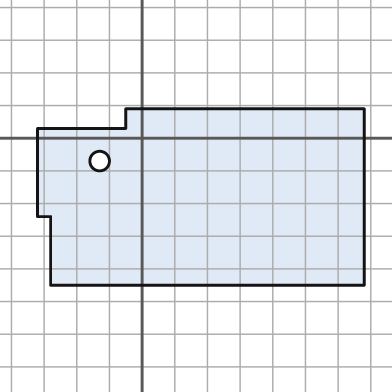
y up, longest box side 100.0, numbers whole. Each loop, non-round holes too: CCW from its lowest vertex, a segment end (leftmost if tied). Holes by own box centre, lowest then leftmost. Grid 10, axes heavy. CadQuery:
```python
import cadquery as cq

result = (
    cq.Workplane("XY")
    .moveTo(-28.0, -45.0)
    .lineTo(68.0, -45.0)
    .lineTo(68.0, 9.0)
    .lineTo(-5.0, 9.0)
    .lineTo(-5.0, 3.0)
    .lineTo(-32.0, 3.0)
    .lineTo(-32.0, -24.0)
    .lineTo(-28.0, -24.0)
    .close()
    .moveTo(-13.0, -7.0)
    .circle(3.0)
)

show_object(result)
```